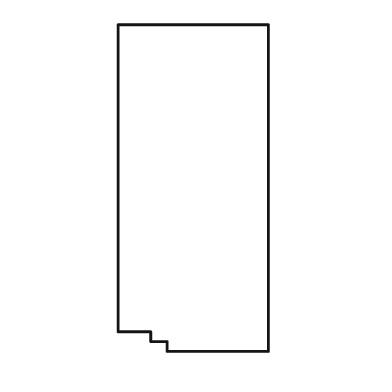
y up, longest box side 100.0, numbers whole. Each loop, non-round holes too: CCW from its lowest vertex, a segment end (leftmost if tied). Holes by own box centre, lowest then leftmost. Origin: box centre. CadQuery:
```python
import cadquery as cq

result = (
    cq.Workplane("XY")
    .moveTo(-8.0, -50.0)
    .lineTo(23.0, -50.0)
    .lineTo(23.0, 50.0)
    .lineTo(-23.0, 50.0)
    .lineTo(-23.0, -44.0)
    .lineTo(-13.0, -44.0)
    .lineTo(-13.0, -47.0)
    .lineTo(-8.0, -47.0)
    .close()
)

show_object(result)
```